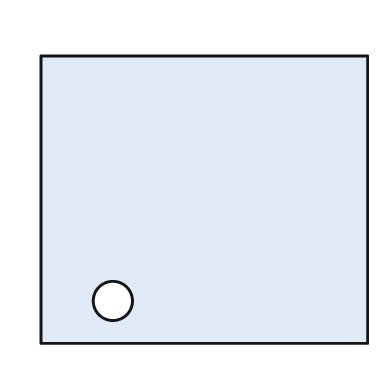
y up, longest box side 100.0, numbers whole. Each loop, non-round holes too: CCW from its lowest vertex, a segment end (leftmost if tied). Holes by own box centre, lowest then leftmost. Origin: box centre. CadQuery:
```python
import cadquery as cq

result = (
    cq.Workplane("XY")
    .moveTo(-50.0, -44.0)
    .lineTo(50.0, -44.0)
    .lineTo(50.0, 44.0)
    .lineTo(-50.0, 44.0)
    .close()
    .moveTo(-28.0, -31.0)
    .circle(6.0)
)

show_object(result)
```